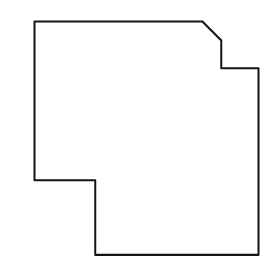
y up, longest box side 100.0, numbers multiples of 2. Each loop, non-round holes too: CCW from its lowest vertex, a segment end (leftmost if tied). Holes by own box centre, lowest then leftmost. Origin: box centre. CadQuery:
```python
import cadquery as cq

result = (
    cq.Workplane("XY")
    .moveTo(-22.0, -50.0)
    .lineTo(48.0, -50.0)
    .lineTo(48.0, 30.0)
    .lineTo(32.0, 30.0)
    .lineTo(32.0, 42.0)
    .lineTo(24.0, 50.0)
    .lineTo(-48.0, 50.0)
    .lineTo(-48.0, -18.0)
    .lineTo(-22.0, -18.0)
    .close()
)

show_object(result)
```